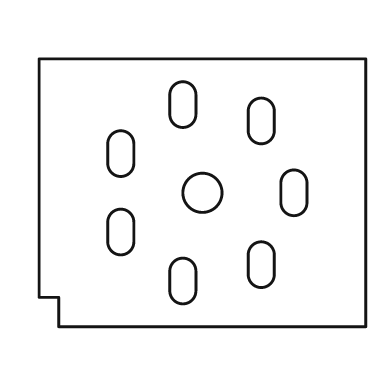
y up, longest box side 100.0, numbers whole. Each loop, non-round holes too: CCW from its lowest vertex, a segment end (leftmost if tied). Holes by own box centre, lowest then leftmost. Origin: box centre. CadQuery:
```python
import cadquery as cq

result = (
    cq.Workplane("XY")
    .moveTo(-44.0, -41.0)
    .lineTo(50.0, -41.0)
    .lineTo(50.0, 41.0)
    .lineTo(-50.0, 41.0)
    .lineTo(-50.0, -32.0)
    .lineTo(-44.0, -32.0)
    .close()
    .moveTo(-10.0, -30.0)
    .threePointArc((-6.0, -34.0), (-2.0, -30.0))
    .lineTo(-2.0, -24.0)
    .threePointArc((-6.0, -20.0), (-10.0, -24.0))
    .close()
    .moveTo(14.0, -25.0)
    .threePointArc((18.0, -29.0), (22.0, -25.0))
    .lineTo(22.0, -19.0)
    .threePointArc((18.0, -15.0), (14.0, -19.0))
    .close()
    .moveTo(-29.0, -15.0)
    .threePointArc((-25.0, -19.0), (-21.0, -15.0))
    .lineTo(-21.0, -9.0)
    .threePointArc((-25.0, -5.0), (-29.0, -9.0))
    .close()
    .moveTo(0.0, 0.0)
    .circle(6.0)
    .moveTo(24.0, -3.0)
    .threePointArc((28.0, -7.0), (32.0, -3.0))
    .lineTo(32.0, 3.0)
    .threePointArc((28.0, 7.0), (24.0, 3.0))
    .close()
    .moveTo(-29.0, 9.0)
    .threePointArc((-25.0, 5.0), (-21.0, 9.0))
    .lineTo(-21.0, 15.0)
    .threePointArc((-25.0, 19.0), (-29.0, 15.0))
    .close()
    .moveTo(14.0, 19.0)
    .threePointArc((18.0, 15.0), (22.0, 19.0))
    .lineTo(22.0, 25.0)
    .threePointArc((18.0, 29.0), (14.0, 25.0))
    .close()
    .moveTo(-10.0, 24.0)
    .threePointArc((-6.0, 20.0), (-2.0, 24.0))
    .lineTo(-2.0, 30.0)
    .threePointArc((-6.0, 34.0), (-10.0, 30.0))
    .close()
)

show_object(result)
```